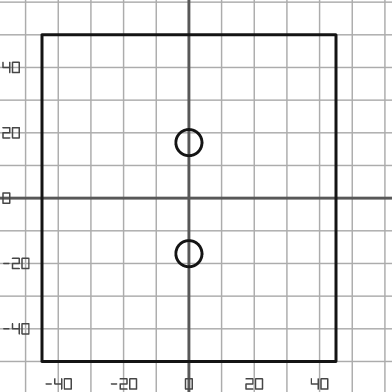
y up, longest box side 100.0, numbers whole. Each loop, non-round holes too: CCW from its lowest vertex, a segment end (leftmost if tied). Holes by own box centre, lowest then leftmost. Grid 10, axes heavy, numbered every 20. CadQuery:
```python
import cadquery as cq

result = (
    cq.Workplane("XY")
    .moveTo(-45.0, -50.0)
    .lineTo(45.0, -50.0)
    .lineTo(45.0, 50.0)
    .lineTo(-45.0, 50.0)
    .close()
    .moveTo(0.0, -17.0)
    .circle(4.0)
    .moveTo(0.0, 17.0)
    .circle(4.0)
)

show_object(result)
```